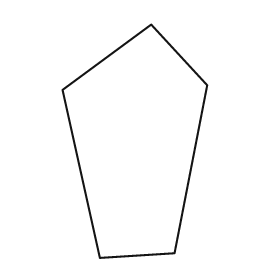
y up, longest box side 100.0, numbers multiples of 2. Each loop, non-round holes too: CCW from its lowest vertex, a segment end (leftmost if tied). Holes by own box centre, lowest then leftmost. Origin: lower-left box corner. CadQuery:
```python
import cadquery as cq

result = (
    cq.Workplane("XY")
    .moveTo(16.0, 0.0)
    .lineTo(48.0, 2.0)
    .lineTo(62.0, 74.0)
    .lineTo(38.0, 100.0)
    .lineTo(0.0, 72.0)
    .close()
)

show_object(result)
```